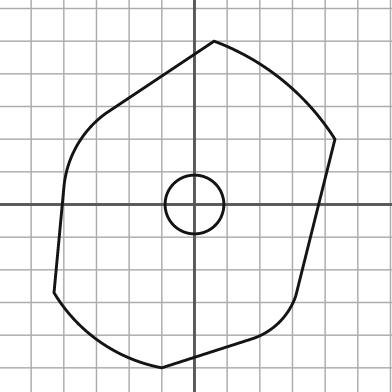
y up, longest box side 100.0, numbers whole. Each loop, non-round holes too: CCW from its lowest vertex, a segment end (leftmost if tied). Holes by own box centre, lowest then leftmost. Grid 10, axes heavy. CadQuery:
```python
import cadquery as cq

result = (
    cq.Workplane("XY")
    .moveTo(-10.0, -50.0)
    .lineTo(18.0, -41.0)
    .threePointArc((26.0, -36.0), (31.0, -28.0))
    .lineTo(43.0, 20.0)
    .threePointArc((27.0, 38.0), (6.0, 50.0))
    .lineTo(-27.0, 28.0)
    .threePointArc((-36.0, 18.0), (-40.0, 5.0))
    .lineTo(-43.0, -27.0)
    .threePointArc((-29.0, -42.0), (-10.0, -50.0))
    .close()
    .moveTo(0.0, 0.0)
    .circle(9.0)
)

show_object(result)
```